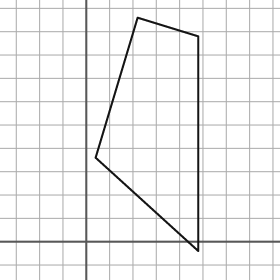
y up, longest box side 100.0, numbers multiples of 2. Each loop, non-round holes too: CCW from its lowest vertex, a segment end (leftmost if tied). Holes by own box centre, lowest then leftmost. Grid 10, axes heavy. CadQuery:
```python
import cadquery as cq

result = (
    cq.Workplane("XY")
    .moveTo(48.0, -4.0)
    .lineTo(48.0, 88.0)
    .lineTo(22.0, 96.0)
    .lineTo(4.0, 36.0)
    .close()
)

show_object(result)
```